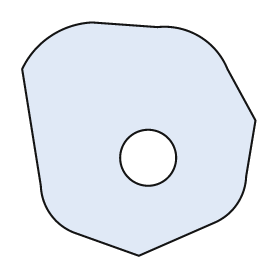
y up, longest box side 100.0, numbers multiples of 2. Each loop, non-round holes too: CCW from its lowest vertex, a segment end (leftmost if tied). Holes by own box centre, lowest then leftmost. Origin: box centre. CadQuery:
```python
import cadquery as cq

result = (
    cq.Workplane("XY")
    .moveTo(0.0, -50.0)
    .lineTo(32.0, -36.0)
    .threePointArc((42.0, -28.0), (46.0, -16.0))
    .lineTo(50.0, 8.0)
    .lineTo(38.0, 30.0)
    .threePointArc((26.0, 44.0), (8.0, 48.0))
    .lineTo(-20.0, 50.0)
    .threePointArc((-38.0, 44.0), (-50.0, 30.0))
    .lineTo(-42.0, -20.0)
    .threePointArc((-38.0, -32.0), (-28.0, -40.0))
    .close()
    .moveTo(4.0, -8.0)
    .circle(12.0)
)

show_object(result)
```